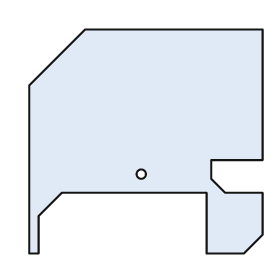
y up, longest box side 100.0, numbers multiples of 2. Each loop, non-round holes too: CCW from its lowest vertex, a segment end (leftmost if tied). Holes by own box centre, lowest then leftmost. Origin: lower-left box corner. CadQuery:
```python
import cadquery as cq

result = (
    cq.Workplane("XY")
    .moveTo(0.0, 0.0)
    .lineTo(4.0, 0.0)
    .lineTo(4.0, 16.0)
    .lineTo(14.0, 26.0)
    .lineTo(76.0, 26.0)
    .lineTo(76.0, 0.0)
    .lineTo(92.0, 0.0)
    .lineTo(100.0, 8.0)
    .lineTo(100.0, 26.0)
    .lineTo(84.0, 26.0)
    .lineTo(78.0, 32.0)
    .lineTo(78.0, 40.0)
    .lineTo(100.0, 40.0)
    .lineTo(100.0, 96.0)
    .lineTo(24.0, 96.0)
    .lineTo(0.0, 72.0)
    .close()
    .moveTo(48.0, 34.0)
    .circle(2.0)
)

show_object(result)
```